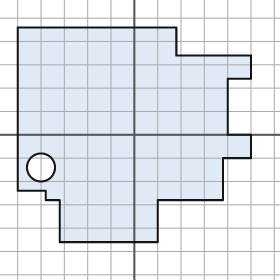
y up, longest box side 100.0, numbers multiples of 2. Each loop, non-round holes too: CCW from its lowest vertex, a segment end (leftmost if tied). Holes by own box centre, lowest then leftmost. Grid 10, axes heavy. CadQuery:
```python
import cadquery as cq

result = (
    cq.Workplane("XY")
    .moveTo(-32.0, -46.0)
    .lineTo(10.0, -46.0)
    .lineTo(10.0, -28.0)
    .lineTo(38.0, -28.0)
    .lineTo(38.0, -10.0)
    .lineTo(50.0, -10.0)
    .lineTo(50.0, 0.0)
    .lineTo(40.0, 0.0)
    .lineTo(40.0, 24.0)
    .lineTo(50.0, 24.0)
    .lineTo(50.0, 34.0)
    .lineTo(18.0, 34.0)
    .lineTo(18.0, 46.0)
    .lineTo(-50.0, 46.0)
    .lineTo(-50.0, -24.0)
    .lineTo(-38.0, -24.0)
    .lineTo(-38.0, -28.0)
    .lineTo(-32.0, -28.0)
    .close()
    .moveTo(-40.0, -14.0)
    .circle(6.0)
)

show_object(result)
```